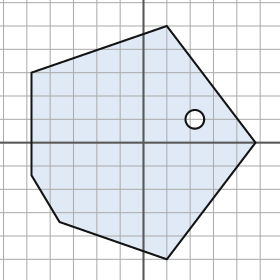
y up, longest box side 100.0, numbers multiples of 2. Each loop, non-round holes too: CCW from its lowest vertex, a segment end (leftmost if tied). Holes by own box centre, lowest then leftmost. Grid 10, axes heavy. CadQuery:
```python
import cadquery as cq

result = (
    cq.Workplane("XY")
    .moveTo(10.0, -50.0)
    .lineTo(48.0, 0.0)
    .lineTo(10.0, 50.0)
    .lineTo(-48.0, 30.0)
    .lineTo(-48.0, -14.0)
    .lineTo(-36.0, -34.0)
    .close()
    .moveTo(22.0, 10.0)
    .circle(4.0)
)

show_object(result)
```